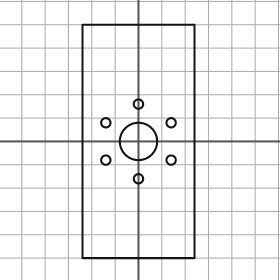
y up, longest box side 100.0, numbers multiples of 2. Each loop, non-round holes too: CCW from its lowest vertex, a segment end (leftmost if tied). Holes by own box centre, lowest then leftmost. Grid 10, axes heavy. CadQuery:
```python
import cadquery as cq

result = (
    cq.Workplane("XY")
    .moveTo(-24.0, -50.0)
    .lineTo(24.0, -50.0)
    .lineTo(24.0, 50.0)
    .lineTo(-24.0, 50.0)
    .close()
    .moveTo(0.0, -16.0)
    .circle(2.0)
    .moveTo(-14.0, -8.0)
    .circle(2.0)
    .moveTo(14.0, -8.0)
    .circle(2.0)
    .moveTo(0.0, 0.0)
    .circle(8.0)
    .moveTo(-14.0, 8.0)
    .circle(2.0)
    .moveTo(14.0, 8.0)
    .circle(2.0)
    .moveTo(0.0, 16.0)
    .circle(2.0)
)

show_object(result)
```